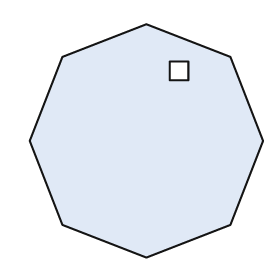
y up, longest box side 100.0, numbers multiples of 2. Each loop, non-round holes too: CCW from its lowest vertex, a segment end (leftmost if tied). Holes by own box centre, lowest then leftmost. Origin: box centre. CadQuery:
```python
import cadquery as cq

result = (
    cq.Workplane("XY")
    .moveTo(0.0, -50.0)
    .lineTo(36.0, -36.0)
    .lineTo(50.0, 0.0)
    .lineTo(36.0, 36.0)
    .lineTo(0.0, 50.0)
    .lineTo(-36.0, 36.0)
    .lineTo(-50.0, 0.0)
    .lineTo(-36.0, -36.0)
    .close()
    .moveTo(10.0, 26.0)
    .lineTo(18.0, 26.0)
    .lineTo(18.0, 34.0)
    .lineTo(10.0, 34.0)
    .close()
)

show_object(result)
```